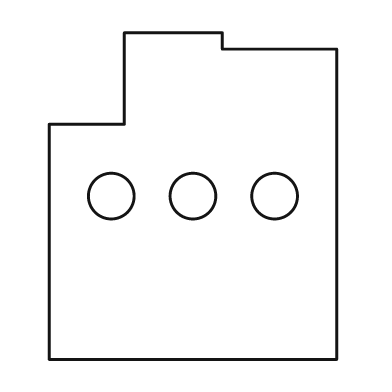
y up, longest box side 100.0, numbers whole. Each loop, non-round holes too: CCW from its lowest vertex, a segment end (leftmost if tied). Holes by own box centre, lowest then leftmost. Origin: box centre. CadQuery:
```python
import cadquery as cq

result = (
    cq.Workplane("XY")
    .moveTo(-44.0, -50.0)
    .lineTo(44.0, -50.0)
    .lineTo(44.0, 45.0)
    .lineTo(9.0, 45.0)
    .lineTo(9.0, 50.0)
    .lineTo(-21.0, 50.0)
    .lineTo(-21.0, 22.0)
    .lineTo(-44.0, 22.0)
    .close()
    .moveTo(-25.0, 0.0)
    .circle(7.0)
    .moveTo(0.0, 0.0)
    .circle(7.0)
    .moveTo(25.0, 0.0)
    .circle(7.0)
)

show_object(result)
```